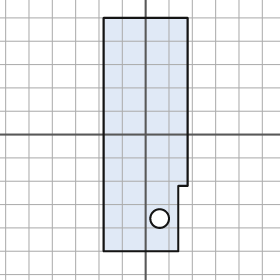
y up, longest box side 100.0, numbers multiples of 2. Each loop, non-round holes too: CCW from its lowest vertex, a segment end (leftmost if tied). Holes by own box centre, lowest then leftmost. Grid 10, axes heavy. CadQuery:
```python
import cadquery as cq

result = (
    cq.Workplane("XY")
    .moveTo(-18.0, -50.0)
    .lineTo(14.0, -50.0)
    .lineTo(14.0, -22.0)
    .lineTo(18.0, -22.0)
    .lineTo(18.0, 50.0)
    .lineTo(-18.0, 50.0)
    .close()
    .moveTo(6.0, -36.0)
    .circle(4.0)
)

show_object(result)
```